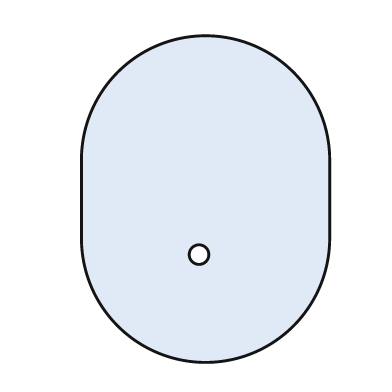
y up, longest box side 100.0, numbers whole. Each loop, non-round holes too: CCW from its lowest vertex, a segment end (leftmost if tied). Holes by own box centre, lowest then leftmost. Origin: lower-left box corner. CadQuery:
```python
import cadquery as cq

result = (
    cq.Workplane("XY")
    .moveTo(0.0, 38.0)
    .threePointArc((38.0, 0.0), (76.0, 38.0))
    .lineTo(76.0, 62.0)
    .threePointArc((38.0, 100.0), (0.0, 62.0))
    .close()
    .moveTo(36.0, 33.0)
    .circle(3.0)
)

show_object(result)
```